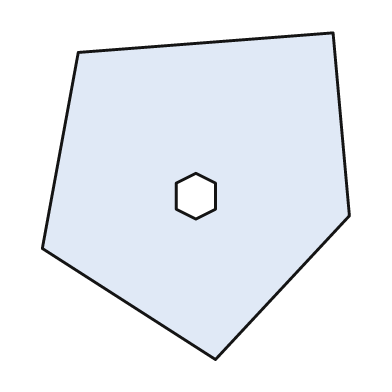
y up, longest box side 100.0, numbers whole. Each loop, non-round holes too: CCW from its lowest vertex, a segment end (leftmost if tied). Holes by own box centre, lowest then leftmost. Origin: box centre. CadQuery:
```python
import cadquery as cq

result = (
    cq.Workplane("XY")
    .moveTo(6.0, -50.0)
    .lineTo(47.0, -6.0)
    .lineTo(42.0, 50.0)
    .lineTo(-36.0, 44.0)
    .lineTo(-47.0, -16.0)
    .close()
    .moveTo(0.0, -7.0)
    .lineTo(6.0, -4.0)
    .lineTo(6.0, 4.0)
    .lineTo(0.0, 7.0)
    .lineTo(-6.0, 4.0)
    .lineTo(-6.0, -4.0)
    .close()
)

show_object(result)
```